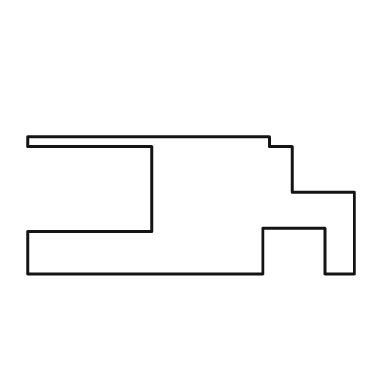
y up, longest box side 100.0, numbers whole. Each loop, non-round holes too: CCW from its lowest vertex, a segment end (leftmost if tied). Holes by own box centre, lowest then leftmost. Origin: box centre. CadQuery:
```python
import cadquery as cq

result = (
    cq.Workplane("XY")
    .moveTo(-50.0, -21.0)
    .lineTo(22.0, -21.0)
    .lineTo(22.0, -7.0)
    .lineTo(41.0, -7.0)
    .lineTo(41.0, -21.0)
    .lineTo(50.0, -21.0)
    .lineTo(50.0, 4.0)
    .lineTo(31.0, 4.0)
    .lineTo(31.0, 18.0)
    .lineTo(24.0, 18.0)
    .lineTo(24.0, 21.0)
    .lineTo(-50.0, 21.0)
    .lineTo(-50.0, 18.0)
    .lineTo(-12.0, 18.0)
    .lineTo(-12.0, -8.0)
    .lineTo(-50.0, -8.0)
    .close()
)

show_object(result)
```